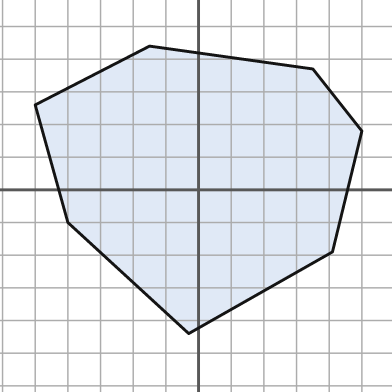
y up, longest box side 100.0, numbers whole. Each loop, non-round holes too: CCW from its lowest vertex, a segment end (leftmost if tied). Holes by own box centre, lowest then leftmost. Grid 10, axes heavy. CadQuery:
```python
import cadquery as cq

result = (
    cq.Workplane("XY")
    .moveTo(-3.0, -44.0)
    .lineTo(41.0, -19.0)
    .lineTo(50.0, 18.0)
    .lineTo(35.0, 37.0)
    .lineTo(-15.0, 44.0)
    .lineTo(-50.0, 26.0)
    .lineTo(-40.0, -10.0)
    .close()
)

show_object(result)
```